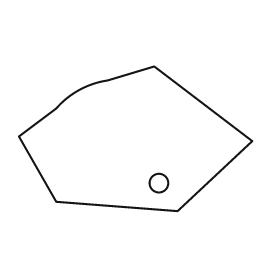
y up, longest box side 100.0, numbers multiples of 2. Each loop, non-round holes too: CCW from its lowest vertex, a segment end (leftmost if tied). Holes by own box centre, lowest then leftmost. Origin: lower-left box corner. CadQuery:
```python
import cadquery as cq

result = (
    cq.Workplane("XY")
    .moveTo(68.0, 0.0)
    .lineTo(100.0, 30.0)
    .lineTo(58.0, 62.0)
    .lineTo(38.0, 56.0)
    .threePointArc((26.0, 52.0), (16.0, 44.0))
    .lineTo(0.0, 32.0)
    .lineTo(16.0, 4.0)
    .close()
    .moveTo(60.0, 12.0)
    .circle(4.0)
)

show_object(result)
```